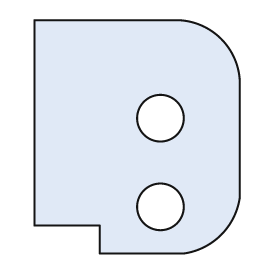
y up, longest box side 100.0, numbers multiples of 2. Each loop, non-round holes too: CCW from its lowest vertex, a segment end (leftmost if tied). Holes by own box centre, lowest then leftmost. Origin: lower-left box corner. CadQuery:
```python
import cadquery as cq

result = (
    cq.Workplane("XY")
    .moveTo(28.0, 0.0)
    .lineTo(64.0, 0.0)
    .threePointArc((80.0, 8.0), (88.0, 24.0))
    .lineTo(88.0, 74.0)
    .threePointArc((80.0, 92.0), (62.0, 100.0))
    .lineTo(0.0, 100.0)
    .lineTo(0.0, 12.0)
    .lineTo(28.0, 12.0)
    .close()
    .moveTo(54.0, 20.0)
    .circle(10.0)
    .moveTo(54.0, 58.0)
    .circle(10.0)
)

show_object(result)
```